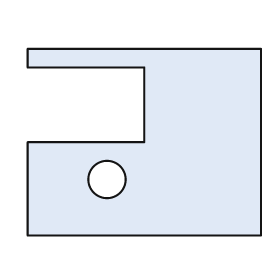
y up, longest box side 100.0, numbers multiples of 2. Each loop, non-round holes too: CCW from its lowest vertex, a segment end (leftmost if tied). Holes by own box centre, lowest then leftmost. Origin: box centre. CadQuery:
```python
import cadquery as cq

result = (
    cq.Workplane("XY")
    .moveTo(-50.0, -40.0)
    .lineTo(50.0, -40.0)
    .lineTo(50.0, 40.0)
    .lineTo(-50.0, 40.0)
    .lineTo(-50.0, 32.0)
    .lineTo(0.0, 32.0)
    .lineTo(0.0, 0.0)
    .lineTo(-50.0, 0.0)
    .close()
    .moveTo(-16.0, -16.0)
    .circle(8.0)
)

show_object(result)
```